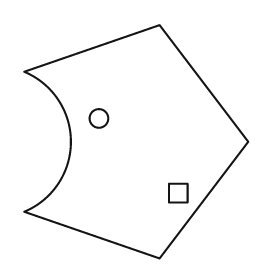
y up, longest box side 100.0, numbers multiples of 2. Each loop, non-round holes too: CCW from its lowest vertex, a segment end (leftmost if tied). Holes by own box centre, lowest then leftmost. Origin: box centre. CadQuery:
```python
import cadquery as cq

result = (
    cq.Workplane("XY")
    .moveTo(10.0, -50.0)
    .lineTo(48.0, 0.0)
    .lineTo(10.0, 50.0)
    .lineTo(-48.0, 30.0)
    .threePointArc((-28.0, 0.0), (-48.0, -30.0))
    .close()
    .moveTo(14.0, -26.0)
    .lineTo(22.0, -26.0)
    .lineTo(22.0, -18.0)
    .lineTo(14.0, -18.0)
    .close()
    .moveTo(-16.0, 10.0)
    .circle(4.0)
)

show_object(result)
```